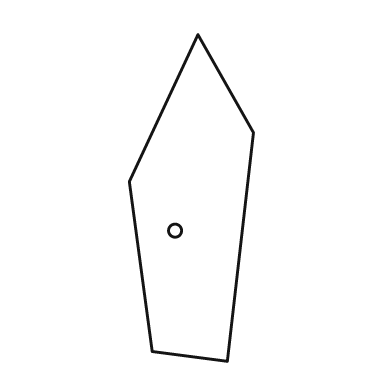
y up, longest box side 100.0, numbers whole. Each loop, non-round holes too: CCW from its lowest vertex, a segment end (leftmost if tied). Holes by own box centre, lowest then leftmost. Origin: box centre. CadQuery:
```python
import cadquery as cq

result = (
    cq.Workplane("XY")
    .moveTo(11.0, -50.0)
    .lineTo(19.0, 20.0)
    .lineTo(2.0, 50.0)
    .lineTo(-19.0, 5.0)
    .lineTo(-12.0, -47.0)
    .close()
    .moveTo(-5.0, -10.0)
    .circle(2.0)
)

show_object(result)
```